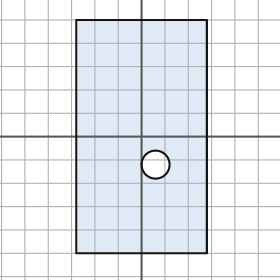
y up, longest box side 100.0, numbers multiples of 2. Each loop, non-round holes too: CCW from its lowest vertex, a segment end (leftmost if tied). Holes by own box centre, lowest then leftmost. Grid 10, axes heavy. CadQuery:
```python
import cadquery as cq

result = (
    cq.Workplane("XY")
    .moveTo(-28.0, -50.0)
    .lineTo(28.0, -50.0)
    .lineTo(28.0, 50.0)
    .lineTo(-28.0, 50.0)
    .close()
    .moveTo(6.0, -12.0)
    .circle(6.0)
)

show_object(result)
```